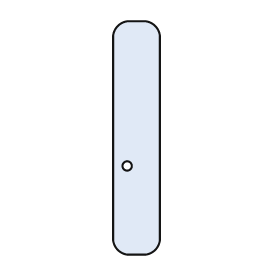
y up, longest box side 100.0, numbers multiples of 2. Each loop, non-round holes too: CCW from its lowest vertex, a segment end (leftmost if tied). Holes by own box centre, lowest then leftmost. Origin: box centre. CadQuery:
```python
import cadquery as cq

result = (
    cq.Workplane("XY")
    .moveTo(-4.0, -50.0)
    .lineTo(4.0, -50.0)
    .threePointArc((8.0, -48.0), (10.0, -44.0))
    .lineTo(10.0, 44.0)
    .threePointArc((8.0, 48.0), (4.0, 50.0))
    .lineTo(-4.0, 50.0)
    .threePointArc((-8.0, 48.0), (-10.0, 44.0))
    .lineTo(-10.0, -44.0)
    .threePointArc((-8.0, -48.0), (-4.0, -50.0))
    .close()
    .moveTo(-4.0, -12.0)
    .circle(2.0)
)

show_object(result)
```